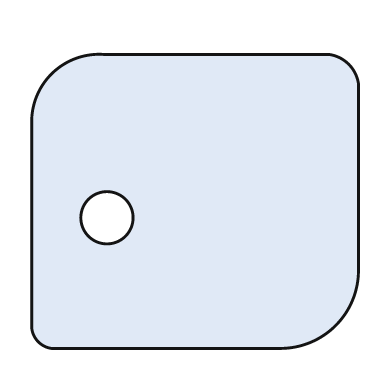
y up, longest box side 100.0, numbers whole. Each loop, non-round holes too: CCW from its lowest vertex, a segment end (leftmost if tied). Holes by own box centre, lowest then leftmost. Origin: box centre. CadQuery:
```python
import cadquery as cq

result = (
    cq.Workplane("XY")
    .moveTo(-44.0, -45.0)
    .lineTo(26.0, -45.0)
    .threePointArc((43.0, -38.0), (50.0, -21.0))
    .lineTo(50.0, 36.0)
    .threePointArc((47.0, 42.0), (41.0, 45.0))
    .lineTo(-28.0, 45.0)
    .threePointArc((-44.0, 39.0), (-50.0, 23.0))
    .lineTo(-50.0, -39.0)
    .threePointArc((-48.0, -43.0), (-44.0, -45.0))
    .close()
    .moveTo(-27.0, -5.0)
    .circle(8.0)
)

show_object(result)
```